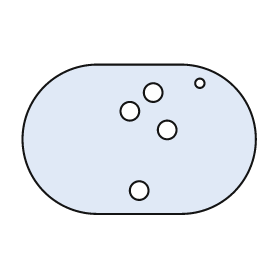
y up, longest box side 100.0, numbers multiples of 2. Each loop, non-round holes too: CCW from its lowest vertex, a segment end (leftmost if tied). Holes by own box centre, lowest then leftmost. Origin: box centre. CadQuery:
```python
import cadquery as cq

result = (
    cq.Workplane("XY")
    .moveTo(-18.0, -32.0)
    .lineTo(18.0, -32.0)
    .threePointArc((50.0, 0.0), (18.0, 32.0))
    .lineTo(-18.0, 32.0)
    .threePointArc((-50.0, 0.0), (-18.0, -32.0))
    .close()
    .moveTo(0.0, -22.0)
    .circle(4.0)
    .moveTo(12.0, 4.0)
    .circle(4.0)
    .moveTo(-4.0, 12.0)
    .circle(4.0)
    .moveTo(6.0, 20.0)
    .circle(4.0)
    .moveTo(26.0, 24.0)
    .circle(2.0)
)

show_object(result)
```